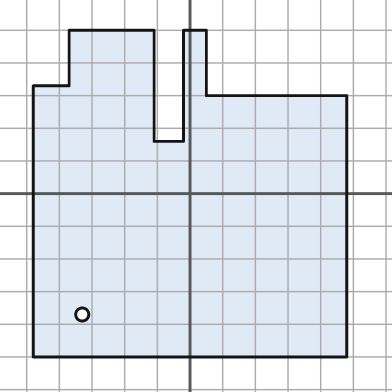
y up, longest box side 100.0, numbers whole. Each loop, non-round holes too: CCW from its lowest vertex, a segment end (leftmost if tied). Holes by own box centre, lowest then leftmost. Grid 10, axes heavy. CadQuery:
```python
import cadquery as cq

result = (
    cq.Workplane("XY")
    .moveTo(-48.0, -50.0)
    .lineTo(48.0, -50.0)
    .lineTo(48.0, 30.0)
    .lineTo(5.0, 30.0)
    .lineTo(5.0, 50.0)
    .lineTo(-2.0, 50.0)
    .lineTo(-2.0, 16.0)
    .lineTo(-11.0, 16.0)
    .lineTo(-11.0, 50.0)
    .lineTo(-37.0, 50.0)
    .lineTo(-37.0, 33.0)
    .lineTo(-48.0, 33.0)
    .close()
    .moveTo(-33.0, -37.0)
    .circle(2.0)
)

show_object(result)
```